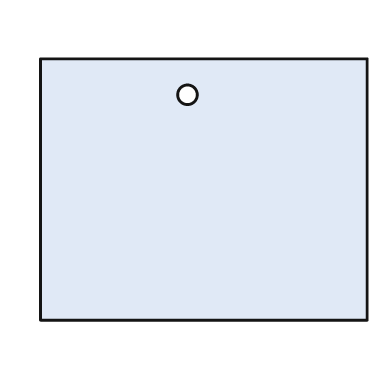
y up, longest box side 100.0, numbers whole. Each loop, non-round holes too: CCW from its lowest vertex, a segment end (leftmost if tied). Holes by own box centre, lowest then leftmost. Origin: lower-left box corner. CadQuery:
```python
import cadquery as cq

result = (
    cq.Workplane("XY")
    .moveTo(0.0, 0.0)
    .lineTo(100.0, 0.0)
    .lineTo(100.0, 80.0)
    .lineTo(0.0, 80.0)
    .close()
    .moveTo(45.0, 69.0)
    .circle(3.0)
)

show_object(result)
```